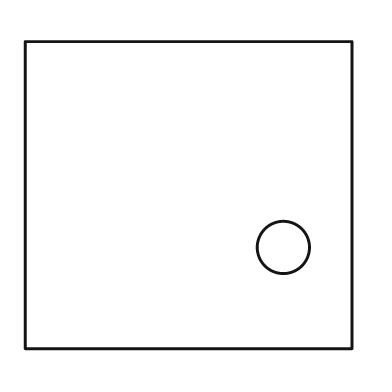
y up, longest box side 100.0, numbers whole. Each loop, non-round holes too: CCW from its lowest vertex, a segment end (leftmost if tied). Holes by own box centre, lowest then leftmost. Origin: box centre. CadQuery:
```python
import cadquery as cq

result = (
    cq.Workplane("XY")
    .moveTo(-50.0, -47.0)
    .lineTo(50.0, -47.0)
    .lineTo(50.0, 47.0)
    .lineTo(-50.0, 47.0)
    .close()
    .moveTo(29.0, -16.0)
    .circle(8.0)
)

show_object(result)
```